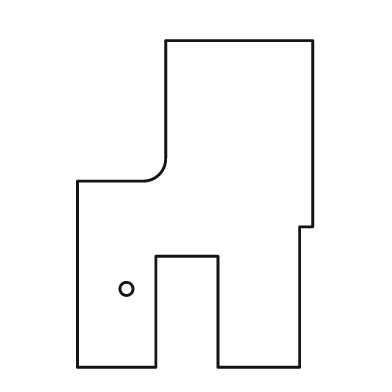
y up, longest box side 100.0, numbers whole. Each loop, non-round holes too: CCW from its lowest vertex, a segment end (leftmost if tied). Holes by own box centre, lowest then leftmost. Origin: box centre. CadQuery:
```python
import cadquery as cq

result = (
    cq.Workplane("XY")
    .moveTo(-36.0, -50.0)
    .lineTo(-12.0, -50.0)
    .lineTo(-12.0, -16.0)
    .lineTo(7.0, -16.0)
    .lineTo(7.0, -50.0)
    .lineTo(32.0, -50.0)
    .lineTo(32.0, -7.0)
    .lineTo(36.0, -7.0)
    .lineTo(36.0, 50.0)
    .lineTo(-9.0, 50.0)
    .lineTo(-9.0, 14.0)
    .threePointArc((-11.0, 9.0), (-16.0, 7.0))
    .lineTo(-36.0, 7.0)
    .close()
    .moveTo(-21.0, -26.0)
    .circle(2.0)
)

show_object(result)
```